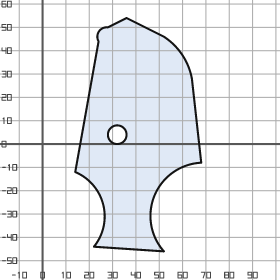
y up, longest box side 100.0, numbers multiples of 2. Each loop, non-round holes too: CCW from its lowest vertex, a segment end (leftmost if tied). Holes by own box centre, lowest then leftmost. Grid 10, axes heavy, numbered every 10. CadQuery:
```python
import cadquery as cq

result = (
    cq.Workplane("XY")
    .moveTo(52.0, -46.0)
    .threePointArc((48.0, -22.0), (68.0, -8.0))
    .lineTo(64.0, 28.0)
    .threePointArc((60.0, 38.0), (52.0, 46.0))
    .lineTo(36.0, 54.0)
    .lineTo(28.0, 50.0)
    .threePointArc((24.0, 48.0), (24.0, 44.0))
    .lineTo(14.0, -12.0)
    .threePointArc((26.0, -26.0), (22.0, -44.0))
    .close()
    .moveTo(32.0, 4.0)
    .circle(4.0)
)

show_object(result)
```